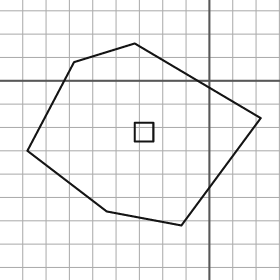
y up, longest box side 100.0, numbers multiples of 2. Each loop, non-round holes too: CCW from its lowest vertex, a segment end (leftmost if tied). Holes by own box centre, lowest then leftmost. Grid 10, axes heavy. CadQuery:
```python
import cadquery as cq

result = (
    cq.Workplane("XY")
    .moveTo(-12.0, -62.0)
    .lineTo(22.0, -16.0)
    .lineTo(-32.0, 16.0)
    .lineTo(-58.0, 8.0)
    .lineTo(-78.0, -30.0)
    .lineTo(-44.0, -56.0)
    .close()
    .moveTo(-32.0, -26.0)
    .lineTo(-24.0, -26.0)
    .lineTo(-24.0, -18.0)
    .lineTo(-32.0, -18.0)
    .close()
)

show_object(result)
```